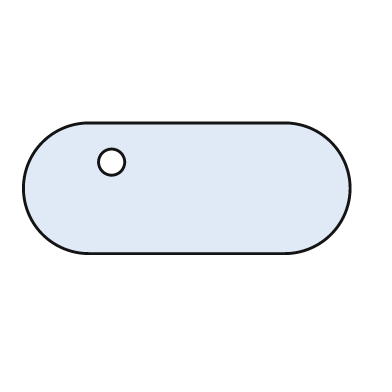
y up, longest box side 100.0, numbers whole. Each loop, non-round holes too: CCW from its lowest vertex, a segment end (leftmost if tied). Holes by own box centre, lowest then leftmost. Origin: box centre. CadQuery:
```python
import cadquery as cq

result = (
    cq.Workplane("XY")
    .moveTo(-30.0, -20.0)
    .lineTo(30.0, -20.0)
    .threePointArc((50.0, 0.0), (30.0, 20.0))
    .lineTo(-30.0, 20.0)
    .threePointArc((-50.0, 0.0), (-30.0, -20.0))
    .close()
    .moveTo(-23.0, 8.0)
    .circle(4.0)
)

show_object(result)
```